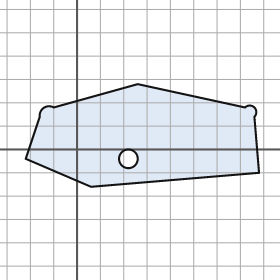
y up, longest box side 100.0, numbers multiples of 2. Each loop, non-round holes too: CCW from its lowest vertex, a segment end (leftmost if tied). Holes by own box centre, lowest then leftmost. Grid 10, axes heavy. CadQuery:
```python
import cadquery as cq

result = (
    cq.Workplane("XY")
    .moveTo(6.0, -16.0)
    .lineTo(78.0, -10.0)
    .lineTo(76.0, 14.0)
    .threePointArc((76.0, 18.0), (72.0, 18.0))
    .lineTo(26.0, 28.0)
    .lineTo(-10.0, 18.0)
    .threePointArc((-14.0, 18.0), (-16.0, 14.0))
    .lineTo(-22.0, -4.0)
    .close()
    .moveTo(22.0, -4.0)
    .circle(4.0)
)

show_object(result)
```